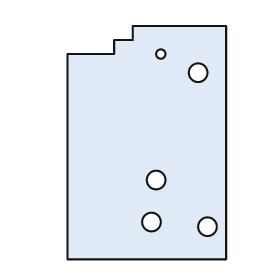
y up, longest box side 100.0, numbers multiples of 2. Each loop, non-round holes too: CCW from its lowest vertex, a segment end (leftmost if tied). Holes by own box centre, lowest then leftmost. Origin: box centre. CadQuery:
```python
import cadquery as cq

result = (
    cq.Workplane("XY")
    .moveTo(-34.0, -50.0)
    .lineTo(34.0, -50.0)
    .lineTo(34.0, 50.0)
    .lineTo(-6.0, 50.0)
    .lineTo(-6.0, 44.0)
    .lineTo(-14.0, 44.0)
    .lineTo(-14.0, 38.0)
    .lineTo(-34.0, 38.0)
    .close()
    .moveTo(26.0, -36.0)
    .circle(4.0)
    .moveTo(2.0, -34.0)
    .circle(4.0)
    .moveTo(4.0, -16.0)
    .circle(4.0)
    .moveTo(22.0, 30.0)
    .circle(4.0)
    .moveTo(6.0, 38.0)
    .circle(2.0)
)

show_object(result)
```